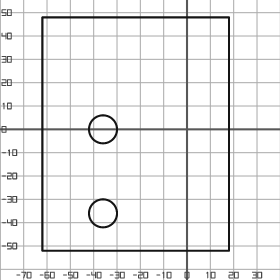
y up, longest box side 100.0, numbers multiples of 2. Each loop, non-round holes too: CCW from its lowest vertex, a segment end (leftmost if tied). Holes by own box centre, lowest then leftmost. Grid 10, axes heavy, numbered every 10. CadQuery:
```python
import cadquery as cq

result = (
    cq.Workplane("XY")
    .moveTo(-62.0, -52.0)
    .lineTo(18.0, -52.0)
    .lineTo(18.0, 48.0)
    .lineTo(-62.0, 48.0)
    .close()
    .moveTo(-36.0, -36.0)
    .circle(6.0)
    .moveTo(-36.0, 0.0)
    .circle(6.0)
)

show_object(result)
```